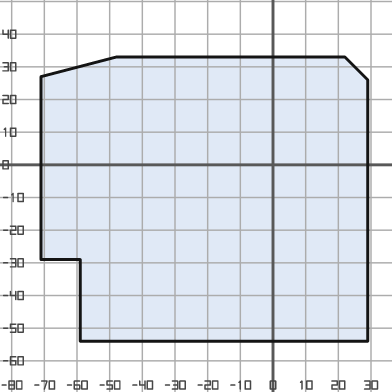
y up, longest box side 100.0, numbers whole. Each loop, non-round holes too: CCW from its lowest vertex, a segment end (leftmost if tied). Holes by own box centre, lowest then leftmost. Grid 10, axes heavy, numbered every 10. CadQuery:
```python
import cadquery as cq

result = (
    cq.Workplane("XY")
    .moveTo(-59.0, -54.0)
    .lineTo(29.0, -54.0)
    .lineTo(29.0, 26.0)
    .lineTo(22.0, 33.0)
    .lineTo(-48.0, 33.0)
    .lineTo(-71.0, 27.0)
    .lineTo(-71.0, -29.0)
    .lineTo(-59.0, -29.0)
    .close()
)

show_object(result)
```